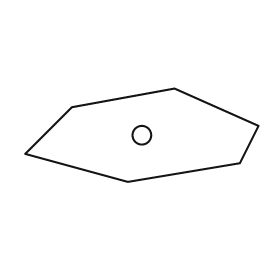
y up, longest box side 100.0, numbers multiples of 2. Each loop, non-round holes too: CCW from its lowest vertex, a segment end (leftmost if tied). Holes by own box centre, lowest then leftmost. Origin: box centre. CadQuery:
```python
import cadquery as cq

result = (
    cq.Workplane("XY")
    .moveTo(-6.0, -20.0)
    .lineTo(42.0, -12.0)
    .lineTo(50.0, 4.0)
    .lineTo(14.0, 20.0)
    .lineTo(-30.0, 12.0)
    .lineTo(-50.0, -8.0)
    .close()
    .moveTo(0.0, 0.0)
    .circle(4.0)
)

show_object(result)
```